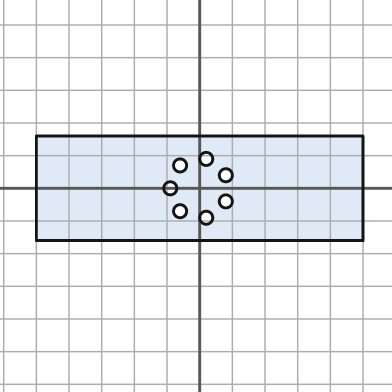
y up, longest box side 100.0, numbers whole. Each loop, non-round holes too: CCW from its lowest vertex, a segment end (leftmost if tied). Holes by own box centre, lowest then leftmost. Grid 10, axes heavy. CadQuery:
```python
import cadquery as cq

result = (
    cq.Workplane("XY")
    .moveTo(-50.0, -16.0)
    .lineTo(50.0, -16.0)
    .lineTo(50.0, 16.0)
    .lineTo(-50.0, 16.0)
    .close()
    .moveTo(2.0, -9.0)
    .circle(2.0)
    .moveTo(-6.0, -7.0)
    .circle(2.0)
    .moveTo(8.0, -4.0)
    .circle(2.0)
    .moveTo(-9.0, 0.0)
    .circle(2.0)
    .moveTo(8.0, 4.0)
    .circle(2.0)
    .moveTo(-6.0, 7.0)
    .circle(2.0)
    .moveTo(2.0, 9.0)
    .circle(2.0)
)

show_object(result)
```